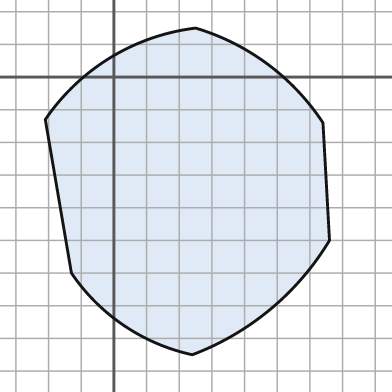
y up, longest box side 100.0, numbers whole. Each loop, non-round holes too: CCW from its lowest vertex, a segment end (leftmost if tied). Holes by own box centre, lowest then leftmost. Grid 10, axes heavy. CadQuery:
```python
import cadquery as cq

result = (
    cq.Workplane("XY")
    .moveTo(24.0, -85.0)
    .threePointArc((48.0, -71.0), (66.0, -50.0))
    .lineTo(64.0, -14.0)
    .threePointArc((47.0, 4.0), (25.0, 15.0))
    .threePointArc((-1.0, 6.0), (-21.0, -13.0))
    .lineTo(-13.0, -60.0)
    .threePointArc((3.0, -76.0), (24.0, -85.0))
    .close()
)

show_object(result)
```